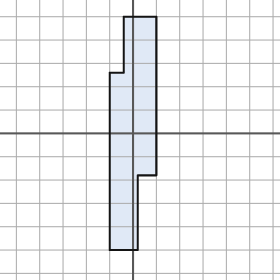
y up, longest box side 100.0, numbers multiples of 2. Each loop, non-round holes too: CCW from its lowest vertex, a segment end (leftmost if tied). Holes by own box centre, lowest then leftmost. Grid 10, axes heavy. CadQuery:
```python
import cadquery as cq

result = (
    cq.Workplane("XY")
    .moveTo(-10.0, -50.0)
    .lineTo(2.0, -50.0)
    .lineTo(2.0, -18.0)
    .lineTo(10.0, -18.0)
    .lineTo(10.0, 50.0)
    .lineTo(-4.0, 50.0)
    .lineTo(-4.0, 26.0)
    .lineTo(-10.0, 26.0)
    .close()
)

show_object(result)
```